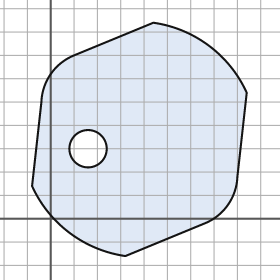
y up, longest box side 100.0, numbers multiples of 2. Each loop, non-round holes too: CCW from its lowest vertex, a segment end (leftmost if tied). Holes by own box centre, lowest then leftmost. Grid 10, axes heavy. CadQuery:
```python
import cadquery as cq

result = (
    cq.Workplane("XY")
    .moveTo(32.0, -16.0)
    .lineTo(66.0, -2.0)
    .threePointArc((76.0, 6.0), (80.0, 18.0))
    .lineTo(84.0, 54.0)
    .threePointArc((68.0, 74.0), (44.0, 84.0))
    .lineTo(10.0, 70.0)
    .threePointArc((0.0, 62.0), (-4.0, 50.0))
    .lineTo(-8.0, 14.0)
    .threePointArc((8.0, -6.0), (32.0, -16.0))
    .close()
    .moveTo(16.0, 30.0)
    .circle(8.0)
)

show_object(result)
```